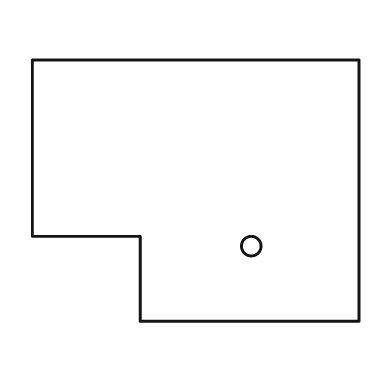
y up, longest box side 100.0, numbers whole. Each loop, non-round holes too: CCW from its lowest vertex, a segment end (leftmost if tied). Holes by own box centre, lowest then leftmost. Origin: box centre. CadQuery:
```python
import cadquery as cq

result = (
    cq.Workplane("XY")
    .moveTo(-17.0, -40.0)
    .lineTo(50.0, -40.0)
    .lineTo(50.0, 40.0)
    .lineTo(-50.0, 40.0)
    .lineTo(-50.0, -14.0)
    .lineTo(-17.0, -14.0)
    .close()
    .moveTo(17.0, -17.0)
    .circle(3.0)
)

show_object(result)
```